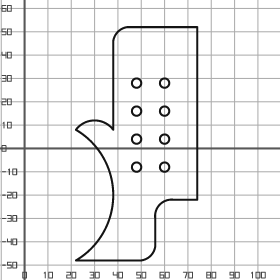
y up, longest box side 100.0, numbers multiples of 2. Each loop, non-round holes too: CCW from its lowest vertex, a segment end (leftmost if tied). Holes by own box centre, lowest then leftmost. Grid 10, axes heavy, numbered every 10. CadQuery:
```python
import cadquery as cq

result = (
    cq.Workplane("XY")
    .moveTo(22.0, -48.0)
    .lineTo(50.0, -48.0)
    .threePointArc((54.0, -46.0), (56.0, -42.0))
    .lineTo(56.0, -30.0)
    .threePointArc((58.0, -24.0), (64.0, -22.0))
    .lineTo(74.0, -22.0)
    .lineTo(74.0, 52.0)
    .lineTo(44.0, 52.0)
    .threePointArc((40.0, 50.0), (38.0, 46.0))
    .lineTo(38.0, 8.0)
    .threePointArc((30.0, 12.0), (22.0, 8.0))
    .threePointArc((38.0, -20.0), (22.0, -48.0))
    .close()
    .moveTo(48.0, -8.0)
    .circle(2.0)
    .moveTo(60.0, -8.0)
    .circle(2.0)
    .moveTo(48.0, 4.0)
    .circle(2.0)
    .moveTo(60.0, 4.0)
    .circle(2.0)
    .moveTo(48.0, 16.0)
    .circle(2.0)
    .moveTo(60.0, 16.0)
    .circle(2.0)
    .moveTo(48.0, 28.0)
    .circle(2.0)
    .moveTo(60.0, 28.0)
    .circle(2.0)
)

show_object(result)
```